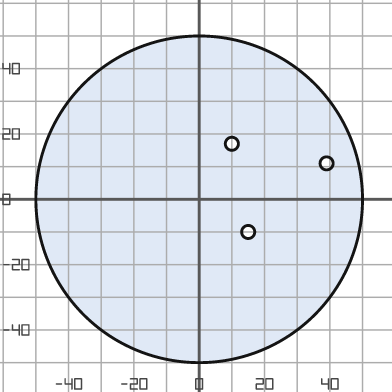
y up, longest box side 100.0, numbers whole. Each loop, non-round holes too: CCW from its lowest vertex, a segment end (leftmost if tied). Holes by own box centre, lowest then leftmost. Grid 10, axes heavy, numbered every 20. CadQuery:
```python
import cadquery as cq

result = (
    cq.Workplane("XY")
    .moveTo(0.0, 0.0)
    .circle(50.0)
    .moveTo(15.0, -10.0)
    .circle(2.0)
    .moveTo(39.0, 11.0)
    .circle(2.0)
    .moveTo(10.0, 17.0)
    .circle(2.0)
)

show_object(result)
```